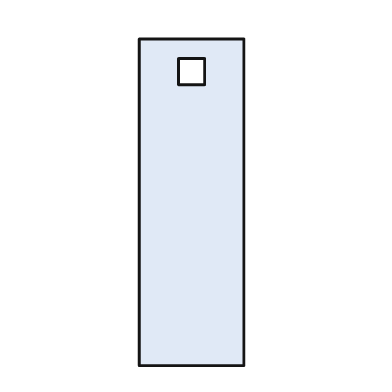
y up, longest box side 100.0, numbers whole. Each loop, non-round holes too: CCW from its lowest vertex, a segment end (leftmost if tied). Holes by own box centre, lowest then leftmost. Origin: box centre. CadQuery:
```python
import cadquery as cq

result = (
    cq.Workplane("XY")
    .moveTo(-16.0, -50.0)
    .lineTo(16.0, -50.0)
    .lineTo(16.0, 50.0)
    .lineTo(-16.0, 50.0)
    .close()
    .moveTo(-4.0, 36.0)
    .lineTo(4.0, 36.0)
    .lineTo(4.0, 44.0)
    .lineTo(-4.0, 44.0)
    .close()
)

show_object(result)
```